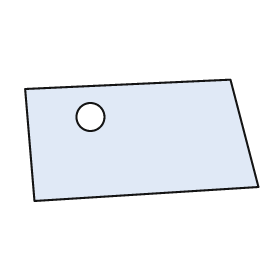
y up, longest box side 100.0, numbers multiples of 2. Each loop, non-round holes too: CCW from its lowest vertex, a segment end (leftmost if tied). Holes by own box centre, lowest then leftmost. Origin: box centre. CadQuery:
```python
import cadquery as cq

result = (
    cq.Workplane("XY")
    .moveTo(-46.0, -26.0)
    .lineTo(50.0, -20.0)
    .lineTo(38.0, 26.0)
    .lineTo(-50.0, 22.0)
    .close()
    .moveTo(-22.0, 10.0)
    .circle(6.0)
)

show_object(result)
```